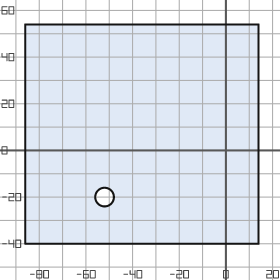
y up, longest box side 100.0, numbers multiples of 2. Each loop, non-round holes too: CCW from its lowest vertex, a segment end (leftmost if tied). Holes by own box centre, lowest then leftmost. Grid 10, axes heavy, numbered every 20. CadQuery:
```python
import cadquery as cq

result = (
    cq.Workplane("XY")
    .moveTo(-86.0, -40.0)
    .lineTo(14.0, -40.0)
    .lineTo(14.0, 54.0)
    .lineTo(-86.0, 54.0)
    .close()
    .moveTo(-52.0, -20.0)
    .circle(4.0)
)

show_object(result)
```